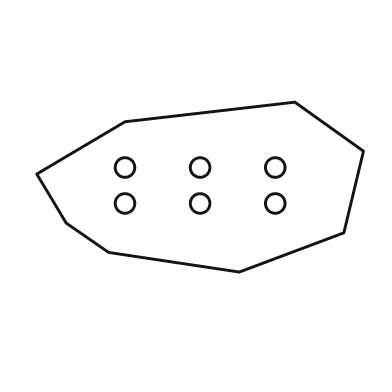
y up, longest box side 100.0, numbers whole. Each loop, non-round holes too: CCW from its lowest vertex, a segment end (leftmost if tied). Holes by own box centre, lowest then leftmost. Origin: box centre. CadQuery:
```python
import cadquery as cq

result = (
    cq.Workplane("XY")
    .moveTo(12.0, -26.0)
    .lineTo(44.0, -14.0)
    .lineTo(50.0, 11.0)
    .lineTo(29.0, 26.0)
    .lineTo(-23.0, 20.0)
    .lineTo(-50.0, 4.0)
    .lineTo(-41.0, -11.0)
    .lineTo(-28.0, -20.0)
    .close()
    .moveTo(-23.0, -5.0)
    .circle(3.0)
    .moveTo(0.0, -5.0)
    .circle(3.0)
    .moveTo(23.0, -5.0)
    .circle(3.0)
    .moveTo(-23.0, 6.0)
    .circle(3.0)
    .moveTo(0.0, 6.0)
    .circle(3.0)
    .moveTo(23.0, 6.0)
    .circle(3.0)
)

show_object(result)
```